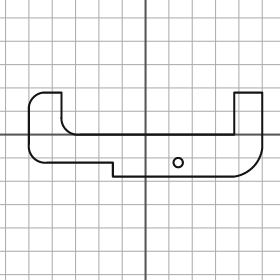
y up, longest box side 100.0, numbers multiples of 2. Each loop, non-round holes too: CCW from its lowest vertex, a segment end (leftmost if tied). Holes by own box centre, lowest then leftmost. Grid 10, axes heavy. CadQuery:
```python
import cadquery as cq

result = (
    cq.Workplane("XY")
    .moveTo(-14.0, -18.0)
    .lineTo(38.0, -18.0)
    .threePointArc((46.0, -14.0), (50.0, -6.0))
    .lineTo(50.0, 18.0)
    .lineTo(38.0, 18.0)
    .lineTo(38.0, 0.0)
    .lineTo(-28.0, 0.0)
    .threePointArc((-34.0, 2.0), (-36.0, 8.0))
    .lineTo(-36.0, 18.0)
    .lineTo(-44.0, 18.0)
    .threePointArc((-48.0, 16.0), (-50.0, 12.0))
    .lineTo(-50.0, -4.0)
    .threePointArc((-48.0, -10.0), (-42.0, -12.0))
    .lineTo(-14.0, -12.0)
    .close()
    .moveTo(14.0, -12.0)
    .circle(2.0)
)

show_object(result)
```